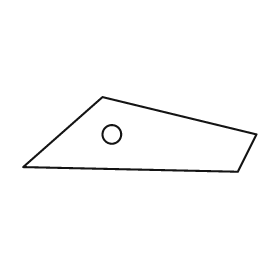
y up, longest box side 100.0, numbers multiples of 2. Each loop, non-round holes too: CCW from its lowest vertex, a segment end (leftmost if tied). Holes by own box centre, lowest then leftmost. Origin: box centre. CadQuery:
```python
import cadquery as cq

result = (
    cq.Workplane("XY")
    .moveTo(42.0, -16.0)
    .lineTo(50.0, 0.0)
    .lineTo(-16.0, 16.0)
    .lineTo(-50.0, -14.0)
    .close()
    .moveTo(-12.0, 0.0)
    .circle(4.0)
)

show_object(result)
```